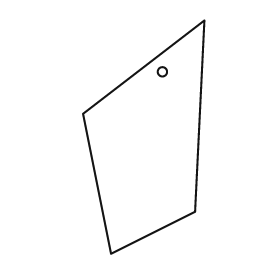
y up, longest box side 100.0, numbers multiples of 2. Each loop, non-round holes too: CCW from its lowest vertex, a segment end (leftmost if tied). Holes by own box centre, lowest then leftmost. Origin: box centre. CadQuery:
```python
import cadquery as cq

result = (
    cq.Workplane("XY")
    .moveTo(-14.0, -50.0)
    .lineTo(22.0, -32.0)
    .lineTo(26.0, 50.0)
    .lineTo(-26.0, 10.0)
    .close()
    .moveTo(8.0, 28.0)
    .circle(2.0)
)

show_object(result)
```